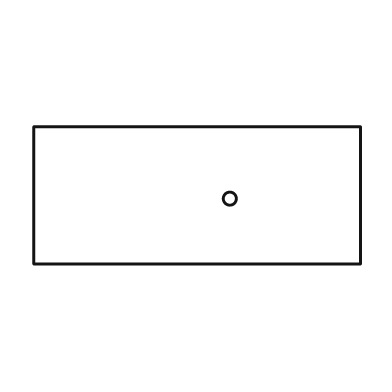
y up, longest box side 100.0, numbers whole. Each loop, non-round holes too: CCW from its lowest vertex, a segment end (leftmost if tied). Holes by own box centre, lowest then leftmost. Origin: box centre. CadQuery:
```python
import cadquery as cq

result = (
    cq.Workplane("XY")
    .moveTo(-50.0, -21.0)
    .lineTo(50.0, -21.0)
    .lineTo(50.0, 21.0)
    .lineTo(-50.0, 21.0)
    .close()
    .moveTo(10.0, -1.0)
    .circle(2.0)
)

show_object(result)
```